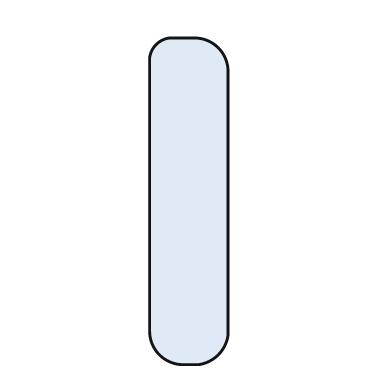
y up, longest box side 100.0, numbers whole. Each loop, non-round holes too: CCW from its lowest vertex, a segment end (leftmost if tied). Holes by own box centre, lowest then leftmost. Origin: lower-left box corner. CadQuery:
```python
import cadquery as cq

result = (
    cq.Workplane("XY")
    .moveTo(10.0, 0.0)
    .lineTo(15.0, 0.0)
    .threePointArc((21.0, 3.0), (24.0, 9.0))
    .lineTo(24.0, 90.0)
    .threePointArc((21.0, 97.0), (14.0, 100.0))
    .lineTo(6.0, 100.0)
    .threePointArc((2.0, 98.0), (0.0, 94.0))
    .lineTo(0.0, 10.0)
    .threePointArc((3.0, 3.0), (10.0, 0.0))
    .close()
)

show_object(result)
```